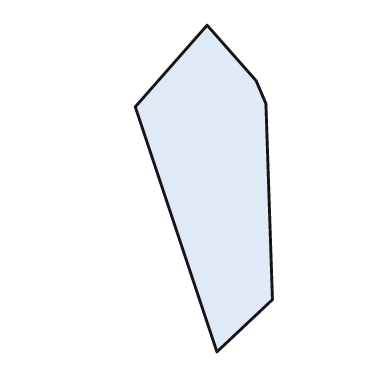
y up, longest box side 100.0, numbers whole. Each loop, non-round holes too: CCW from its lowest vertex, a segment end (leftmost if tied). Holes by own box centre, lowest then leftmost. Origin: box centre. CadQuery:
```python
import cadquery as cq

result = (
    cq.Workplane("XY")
    .moveTo(4.0, -50.0)
    .lineTo(21.0, -34.0)
    .lineTo(19.0, 26.0)
    .lineTo(16.0, 33.0)
    .lineTo(1.0, 50.0)
    .lineTo(-21.0, 25.0)
    .close()
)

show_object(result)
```